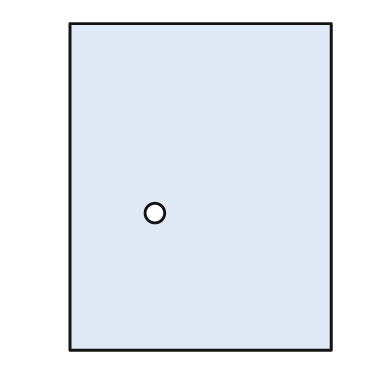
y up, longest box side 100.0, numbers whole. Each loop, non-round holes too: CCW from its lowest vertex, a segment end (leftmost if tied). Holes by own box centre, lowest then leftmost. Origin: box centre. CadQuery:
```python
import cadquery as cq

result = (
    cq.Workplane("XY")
    .moveTo(-40.0, -50.0)
    .lineTo(40.0, -50.0)
    .lineTo(40.0, 50.0)
    .lineTo(-40.0, 50.0)
    .close()
    .moveTo(-14.0, -8.0)
    .circle(3.0)
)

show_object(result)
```